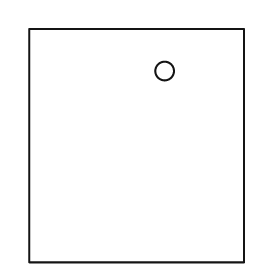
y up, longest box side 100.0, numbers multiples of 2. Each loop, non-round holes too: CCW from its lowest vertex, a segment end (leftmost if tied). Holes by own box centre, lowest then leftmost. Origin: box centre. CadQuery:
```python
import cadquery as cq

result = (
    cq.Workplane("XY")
    .moveTo(-46.0, -50.0)
    .lineTo(46.0, -50.0)
    .lineTo(46.0, 50.0)
    .lineTo(-46.0, 50.0)
    .close()
    .moveTo(12.0, 32.0)
    .circle(4.0)
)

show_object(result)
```